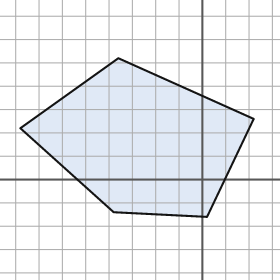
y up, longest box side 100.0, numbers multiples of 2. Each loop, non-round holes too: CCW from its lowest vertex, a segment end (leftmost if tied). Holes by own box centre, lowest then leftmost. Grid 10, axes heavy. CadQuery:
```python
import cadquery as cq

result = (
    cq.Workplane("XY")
    .moveTo(2.0, -16.0)
    .lineTo(22.0, 26.0)
    .lineTo(-36.0, 52.0)
    .lineTo(-78.0, 22.0)
    .lineTo(-38.0, -14.0)
    .close()
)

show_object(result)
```